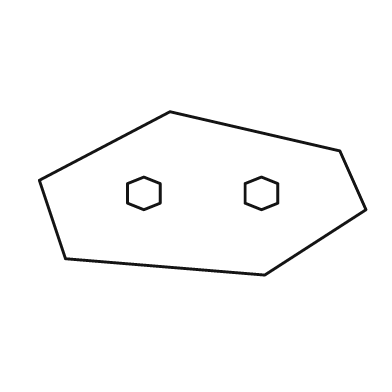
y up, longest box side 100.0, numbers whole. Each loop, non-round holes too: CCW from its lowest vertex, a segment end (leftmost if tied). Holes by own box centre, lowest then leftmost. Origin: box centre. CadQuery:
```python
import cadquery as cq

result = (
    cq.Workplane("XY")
    .moveTo(19.0, -25.0)
    .lineTo(50.0, -5.0)
    .lineTo(42.0, 13.0)
    .lineTo(-10.0, 25.0)
    .lineTo(-50.0, 4.0)
    .lineTo(-42.0, -20.0)
    .close()
    .moveTo(-18.0, -5.0)
    .lineTo(-13.0, -3.0)
    .lineTo(-13.0, 3.0)
    .lineTo(-18.0, 5.0)
    .lineTo(-23.0, 3.0)
    .lineTo(-23.0, -3.0)
    .close()
    .moveTo(18.0, -5.0)
    .lineTo(23.0, -3.0)
    .lineTo(23.0, 3.0)
    .lineTo(18.0, 5.0)
    .lineTo(13.0, 3.0)
    .lineTo(13.0, -3.0)
    .close()
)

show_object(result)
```